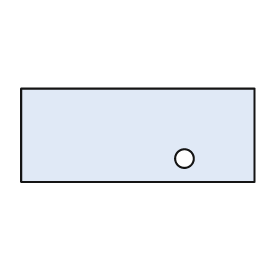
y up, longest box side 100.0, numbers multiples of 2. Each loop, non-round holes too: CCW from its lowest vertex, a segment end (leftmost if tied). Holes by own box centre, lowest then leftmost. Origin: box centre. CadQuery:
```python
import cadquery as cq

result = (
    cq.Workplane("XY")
    .moveTo(-50.0, -20.0)
    .lineTo(50.0, -20.0)
    .lineTo(50.0, 20.0)
    .lineTo(-50.0, 20.0)
    .close()
    .moveTo(20.0, -10.0)
    .circle(4.0)
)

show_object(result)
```